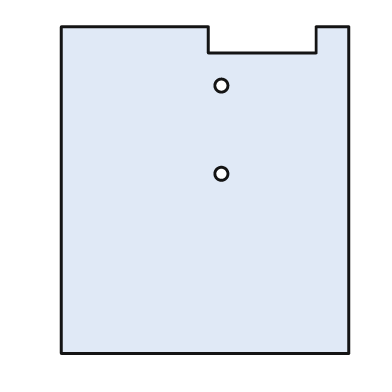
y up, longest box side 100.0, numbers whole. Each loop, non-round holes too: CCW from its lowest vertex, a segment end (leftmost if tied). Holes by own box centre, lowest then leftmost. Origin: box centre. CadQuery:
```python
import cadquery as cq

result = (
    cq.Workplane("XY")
    .moveTo(-44.0, -50.0)
    .lineTo(44.0, -50.0)
    .lineTo(44.0, 50.0)
    .lineTo(34.0, 50.0)
    .lineTo(34.0, 42.0)
    .lineTo(1.0, 42.0)
    .lineTo(1.0, 50.0)
    .lineTo(-44.0, 50.0)
    .close()
    .moveTo(5.0, 5.0)
    .circle(2.0)
    .moveTo(5.0, 32.0)
    .circle(2.0)
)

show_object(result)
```